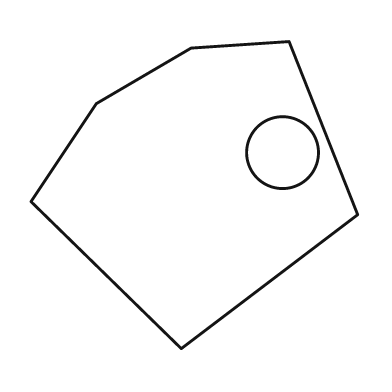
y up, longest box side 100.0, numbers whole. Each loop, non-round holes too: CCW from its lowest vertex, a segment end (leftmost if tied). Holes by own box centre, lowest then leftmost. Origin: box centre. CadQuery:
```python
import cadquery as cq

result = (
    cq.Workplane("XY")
    .moveTo(-4.0, -47.0)
    .lineTo(50.0, -6.0)
    .lineTo(29.0, 47.0)
    .lineTo(-1.0, 45.0)
    .lineTo(-30.0, 28.0)
    .lineTo(-50.0, -2.0)
    .close()
    .moveTo(27.0, 13.0)
    .circle(11.0)
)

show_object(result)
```